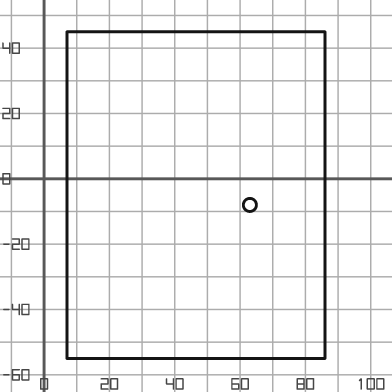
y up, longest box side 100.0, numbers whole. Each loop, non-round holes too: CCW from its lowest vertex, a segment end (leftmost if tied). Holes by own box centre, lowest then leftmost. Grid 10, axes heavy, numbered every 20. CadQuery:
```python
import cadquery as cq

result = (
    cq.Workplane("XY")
    .moveTo(7.0, -55.0)
    .lineTo(86.0, -55.0)
    .lineTo(86.0, 45.0)
    .lineTo(7.0, 45.0)
    .close()
    .moveTo(63.0, -8.0)
    .circle(2.0)
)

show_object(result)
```